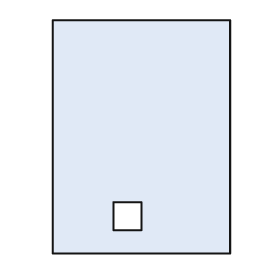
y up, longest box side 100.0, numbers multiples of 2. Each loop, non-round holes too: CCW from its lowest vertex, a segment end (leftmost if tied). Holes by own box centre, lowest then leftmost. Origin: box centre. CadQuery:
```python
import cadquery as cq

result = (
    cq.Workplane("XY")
    .moveTo(-38.0, -50.0)
    .lineTo(38.0, -50.0)
    .lineTo(38.0, 50.0)
    .lineTo(-38.0, 50.0)
    .close()
    .moveTo(-12.0, -40.0)
    .lineTo(0.0, -40.0)
    .lineTo(0.0, -28.0)
    .lineTo(-12.0, -28.0)
    .close()
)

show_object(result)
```